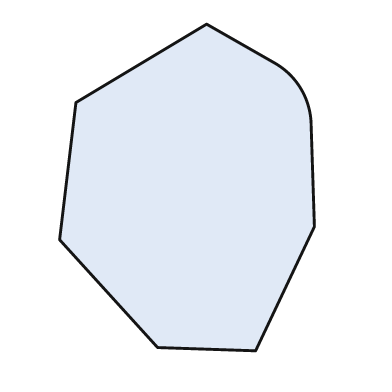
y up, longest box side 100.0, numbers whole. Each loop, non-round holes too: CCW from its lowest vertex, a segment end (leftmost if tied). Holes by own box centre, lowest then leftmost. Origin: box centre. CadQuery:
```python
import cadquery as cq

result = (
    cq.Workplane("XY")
    .moveTo(21.0, -50.0)
    .lineTo(39.0, -12.0)
    .lineTo(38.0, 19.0)
    .threePointArc((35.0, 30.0), (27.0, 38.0))
    .lineTo(6.0, 50.0)
    .lineTo(-34.0, 26.0)
    .lineTo(-39.0, -16.0)
    .lineTo(-9.0, -49.0)
    .close()
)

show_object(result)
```